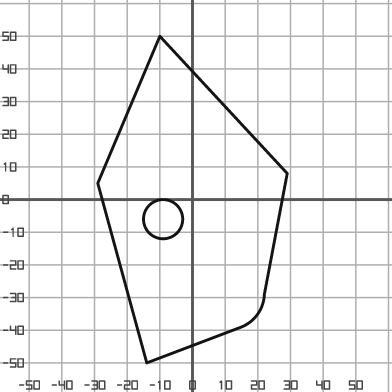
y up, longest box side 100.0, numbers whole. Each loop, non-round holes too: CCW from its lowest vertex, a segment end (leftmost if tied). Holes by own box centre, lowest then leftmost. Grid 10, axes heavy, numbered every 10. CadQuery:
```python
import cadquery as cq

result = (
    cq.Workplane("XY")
    .moveTo(-14.0, -50.0)
    .lineTo(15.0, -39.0)
    .threePointArc((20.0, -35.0), (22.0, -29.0))
    .lineTo(29.0, 8.0)
    .lineTo(-10.0, 50.0)
    .lineTo(-29.0, 5.0)
    .close()
    .moveTo(-9.0, -6.0)
    .circle(6.0)
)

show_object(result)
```